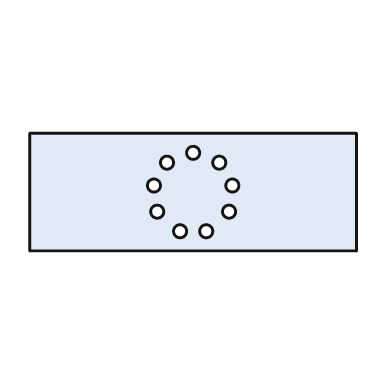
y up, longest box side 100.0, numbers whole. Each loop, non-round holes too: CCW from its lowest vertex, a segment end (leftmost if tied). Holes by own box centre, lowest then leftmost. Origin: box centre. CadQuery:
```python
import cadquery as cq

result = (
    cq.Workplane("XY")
    .moveTo(-50.0, -18.0)
    .lineTo(50.0, -18.0)
    .lineTo(50.0, 18.0)
    .lineTo(-50.0, 18.0)
    .close()
    .moveTo(-4.0, -12.0)
    .circle(2.0)
    .moveTo(4.0, -12.0)
    .circle(2.0)
    .moveTo(-11.0, -6.0)
    .circle(2.0)
    .moveTo(11.0, -6.0)
    .circle(2.0)
    .moveTo(-12.0, 2.0)
    .circle(2.0)
    .moveTo(12.0, 2.0)
    .circle(2.0)
    .moveTo(-8.0, 9.0)
    .circle(2.0)
    .moveTo(8.0, 9.0)
    .circle(2.0)
    .moveTo(0.0, 12.0)
    .circle(2.0)
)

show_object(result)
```